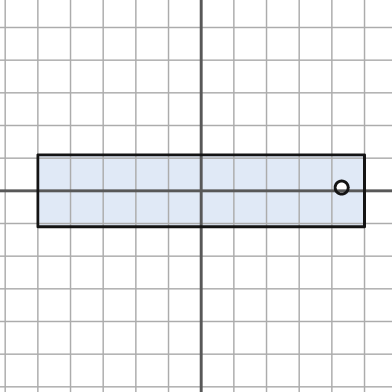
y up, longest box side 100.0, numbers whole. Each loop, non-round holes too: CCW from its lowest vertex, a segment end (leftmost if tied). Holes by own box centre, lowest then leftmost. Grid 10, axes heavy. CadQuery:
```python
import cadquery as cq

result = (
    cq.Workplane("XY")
    .moveTo(-50.0, -11.0)
    .lineTo(50.0, -11.0)
    .lineTo(50.0, 11.0)
    .lineTo(-50.0, 11.0)
    .close()
    .moveTo(43.0, 1.0)
    .circle(2.0)
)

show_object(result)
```